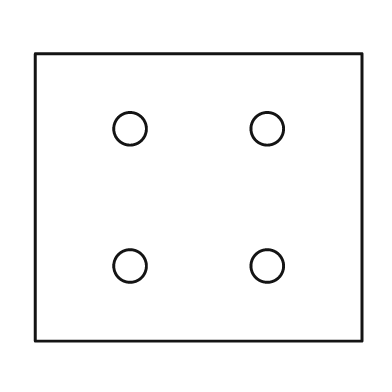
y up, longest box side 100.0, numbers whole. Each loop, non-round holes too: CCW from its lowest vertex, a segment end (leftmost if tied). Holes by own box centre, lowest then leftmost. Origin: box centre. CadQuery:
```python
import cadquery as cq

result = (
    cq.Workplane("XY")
    .moveTo(-50.0, -44.0)
    .lineTo(50.0, -44.0)
    .lineTo(50.0, 44.0)
    .lineTo(-50.0, 44.0)
    .close()
    .moveTo(-21.0, -21.0)
    .circle(5.0)
    .moveTo(21.0, -21.0)
    .circle(5.0)
    .moveTo(-21.0, 21.0)
    .circle(5.0)
    .moveTo(21.0, 21.0)
    .circle(5.0)
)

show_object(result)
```